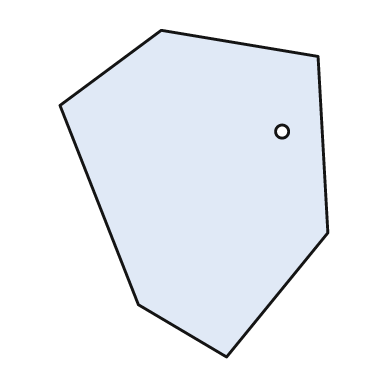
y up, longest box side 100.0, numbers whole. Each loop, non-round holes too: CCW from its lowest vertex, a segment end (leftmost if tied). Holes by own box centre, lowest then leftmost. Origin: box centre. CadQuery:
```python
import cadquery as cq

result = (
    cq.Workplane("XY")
    .moveTo(10.0, -50.0)
    .lineTo(41.0, -12.0)
    .lineTo(38.0, 42.0)
    .lineTo(-10.0, 50.0)
    .lineTo(-41.0, 27.0)
    .lineTo(-17.0, -34.0)
    .close()
    .moveTo(27.0, 19.0)
    .circle(2.0)
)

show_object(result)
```